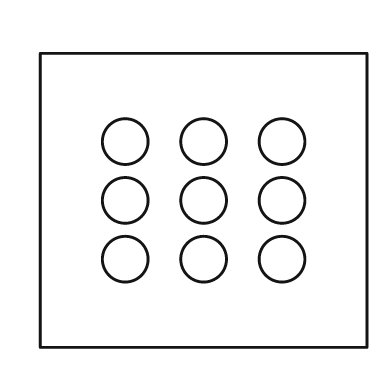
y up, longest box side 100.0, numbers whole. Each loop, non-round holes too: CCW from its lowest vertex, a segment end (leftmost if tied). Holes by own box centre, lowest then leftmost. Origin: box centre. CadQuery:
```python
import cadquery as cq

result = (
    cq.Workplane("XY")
    .moveTo(-50.0, -45.0)
    .lineTo(50.0, -45.0)
    .lineTo(50.0, 45.0)
    .lineTo(-50.0, 45.0)
    .close()
    .moveTo(-24.0, -18.0)
    .circle(7.0)
    .moveTo(0.0, -18.0)
    .circle(7.0)
    .moveTo(24.0, -18.0)
    .circle(7.0)
    .moveTo(-24.0, 0.0)
    .circle(7.0)
    .moveTo(0.0, 0.0)
    .circle(7.0)
    .moveTo(24.0, 0.0)
    .circle(7.0)
    .moveTo(-24.0, 18.0)
    .circle(7.0)
    .moveTo(0.0, 18.0)
    .circle(7.0)
    .moveTo(24.0, 18.0)
    .circle(7.0)
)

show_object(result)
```